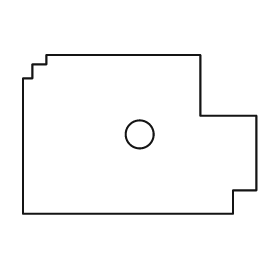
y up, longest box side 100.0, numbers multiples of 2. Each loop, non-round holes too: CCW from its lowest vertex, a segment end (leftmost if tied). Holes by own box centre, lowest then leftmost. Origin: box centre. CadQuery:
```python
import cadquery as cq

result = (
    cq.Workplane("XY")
    .moveTo(-50.0, -34.0)
    .lineTo(40.0, -34.0)
    .lineTo(40.0, -24.0)
    .lineTo(50.0, -24.0)
    .lineTo(50.0, 8.0)
    .lineTo(26.0, 8.0)
    .lineTo(26.0, 34.0)
    .lineTo(-40.0, 34.0)
    .lineTo(-40.0, 30.0)
    .lineTo(-46.0, 30.0)
    .lineTo(-46.0, 24.0)
    .lineTo(-50.0, 24.0)
    .close()
    .moveTo(0.0, 0.0)
    .circle(6.0)
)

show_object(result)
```